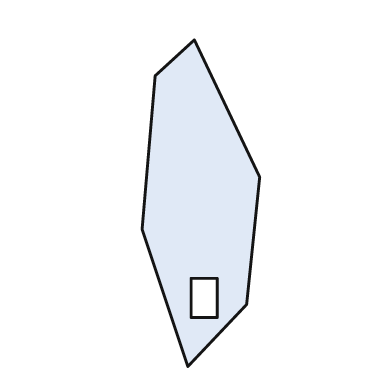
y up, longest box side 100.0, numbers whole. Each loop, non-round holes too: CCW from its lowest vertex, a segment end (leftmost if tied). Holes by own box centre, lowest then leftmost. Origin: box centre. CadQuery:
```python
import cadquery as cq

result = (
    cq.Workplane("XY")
    .moveTo(-4.0, -50.0)
    .lineTo(14.0, -31.0)
    .lineTo(18.0, 8.0)
    .lineTo(-2.0, 50.0)
    .lineTo(-14.0, 39.0)
    .lineTo(-18.0, -8.0)
    .close()
    .moveTo(-3.0, -35.0)
    .lineTo(5.0, -35.0)
    .lineTo(5.0, -23.0)
    .lineTo(-3.0, -23.0)
    .close()
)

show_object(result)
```